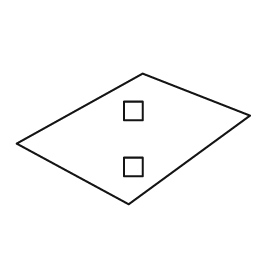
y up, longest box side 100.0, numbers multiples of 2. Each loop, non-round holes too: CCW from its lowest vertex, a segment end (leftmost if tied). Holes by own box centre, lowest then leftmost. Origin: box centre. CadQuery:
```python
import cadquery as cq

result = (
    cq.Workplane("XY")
    .moveTo(-2.0, -28.0)
    .lineTo(50.0, 10.0)
    .lineTo(4.0, 28.0)
    .lineTo(-50.0, -2.0)
    .close()
    .moveTo(-4.0, -16.0)
    .lineTo(4.0, -16.0)
    .lineTo(4.0, -8.0)
    .lineTo(-4.0, -8.0)
    .close()
    .moveTo(-4.0, 8.0)
    .lineTo(4.0, 8.0)
    .lineTo(4.0, 16.0)
    .lineTo(-4.0, 16.0)
    .close()
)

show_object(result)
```